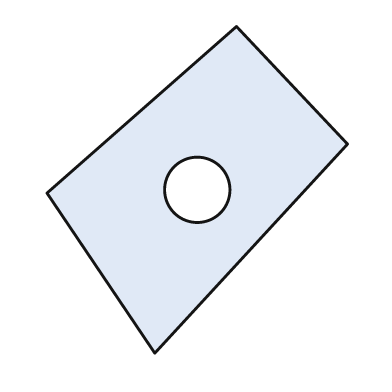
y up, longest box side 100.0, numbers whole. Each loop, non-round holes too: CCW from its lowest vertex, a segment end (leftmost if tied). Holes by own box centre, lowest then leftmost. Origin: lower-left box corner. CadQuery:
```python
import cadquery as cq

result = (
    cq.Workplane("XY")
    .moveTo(33.0, 0.0)
    .lineTo(92.0, 64.0)
    .lineTo(58.0, 100.0)
    .lineTo(0.0, 49.0)
    .close()
    .moveTo(46.0, 50.0)
    .circle(10.0)
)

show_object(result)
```